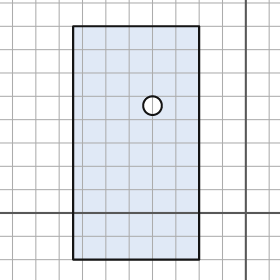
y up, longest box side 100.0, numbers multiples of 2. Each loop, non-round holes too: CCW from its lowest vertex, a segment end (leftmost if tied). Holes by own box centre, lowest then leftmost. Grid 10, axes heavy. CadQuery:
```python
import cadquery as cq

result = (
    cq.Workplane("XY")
    .moveTo(-74.0, -20.0)
    .lineTo(-20.0, -20.0)
    .lineTo(-20.0, 80.0)
    .lineTo(-74.0, 80.0)
    .close()
    .moveTo(-40.0, 46.0)
    .circle(4.0)
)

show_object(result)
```